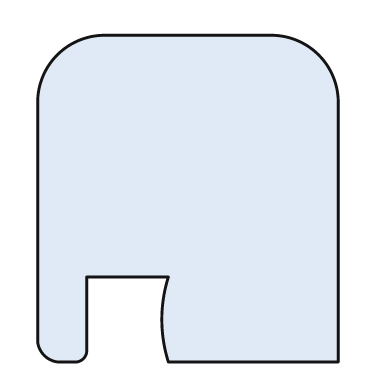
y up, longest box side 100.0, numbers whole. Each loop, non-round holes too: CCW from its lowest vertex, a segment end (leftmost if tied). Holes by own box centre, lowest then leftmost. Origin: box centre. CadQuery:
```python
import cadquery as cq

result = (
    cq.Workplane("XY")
    .moveTo(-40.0, -50.0)
    .lineTo(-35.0, -50.0)
    .threePointArc((-32.0, -49.0), (-31.0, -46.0))
    .lineTo(-31.0, -24.0)
    .lineTo(-6.0, -24.0)
    .threePointArc((-8.0, -37.0), (-6.0, -50.0))
    .lineTo(46.0, -50.0)
    .lineTo(46.0, 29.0)
    .threePointArc((40.0, 44.0), (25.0, 50.0))
    .lineTo(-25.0, 50.0)
    .threePointArc((-40.0, 44.0), (-46.0, 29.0))
    .lineTo(-46.0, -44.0)
    .threePointArc((-44.0, -48.0), (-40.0, -50.0))
    .close()
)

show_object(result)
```